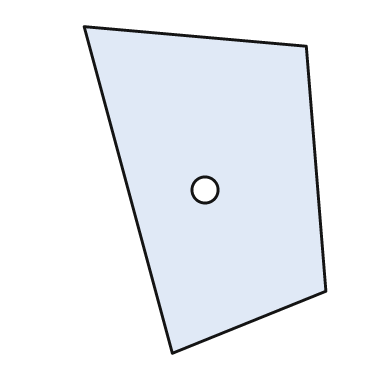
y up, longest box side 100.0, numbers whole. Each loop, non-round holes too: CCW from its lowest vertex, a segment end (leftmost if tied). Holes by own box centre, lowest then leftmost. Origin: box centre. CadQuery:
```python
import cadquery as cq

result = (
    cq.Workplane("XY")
    .moveTo(-10.0, -50.0)
    .lineTo(37.0, -31.0)
    .lineTo(31.0, 44.0)
    .lineTo(-37.0, 50.0)
    .close()
    .moveTo(0.0, 0.0)
    .circle(4.0)
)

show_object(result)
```